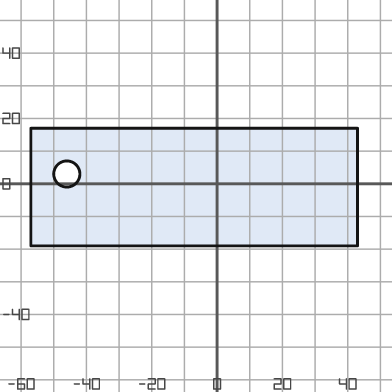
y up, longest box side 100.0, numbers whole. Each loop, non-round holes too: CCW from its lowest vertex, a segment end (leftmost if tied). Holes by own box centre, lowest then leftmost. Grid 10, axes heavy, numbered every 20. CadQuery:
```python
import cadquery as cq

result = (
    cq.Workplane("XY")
    .moveTo(-57.0, -19.0)
    .lineTo(43.0, -19.0)
    .lineTo(43.0, 17.0)
    .lineTo(-57.0, 17.0)
    .close()
    .moveTo(-46.0, 3.0)
    .circle(4.0)
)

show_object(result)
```